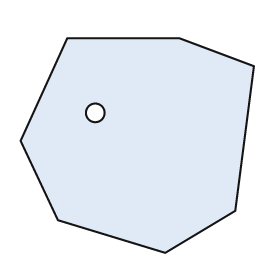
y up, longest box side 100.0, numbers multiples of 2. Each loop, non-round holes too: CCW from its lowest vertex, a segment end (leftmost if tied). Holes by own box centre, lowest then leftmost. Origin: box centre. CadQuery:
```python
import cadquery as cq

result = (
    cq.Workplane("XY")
    .moveTo(12.0, -46.0)
    .lineTo(42.0, -28.0)
    .lineTo(50.0, 34.0)
    .lineTo(18.0, 46.0)
    .lineTo(-30.0, 46.0)
    .lineTo(-50.0, 2.0)
    .lineTo(-34.0, -32.0)
    .close()
    .moveTo(-18.0, 14.0)
    .circle(4.0)
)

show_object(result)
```